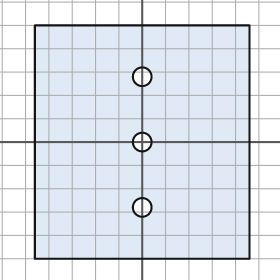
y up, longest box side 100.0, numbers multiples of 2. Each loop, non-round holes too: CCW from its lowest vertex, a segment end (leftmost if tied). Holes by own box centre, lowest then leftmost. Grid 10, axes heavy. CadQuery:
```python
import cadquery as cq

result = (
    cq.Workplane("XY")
    .moveTo(-46.0, -50.0)
    .lineTo(46.0, -50.0)
    .lineTo(46.0, 50.0)
    .lineTo(-46.0, 50.0)
    .close()
    .moveTo(0.0, -28.0)
    .circle(4.0)
    .moveTo(0.0, 0.0)
    .circle(4.0)
    .moveTo(0.0, 28.0)
    .circle(4.0)
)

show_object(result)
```